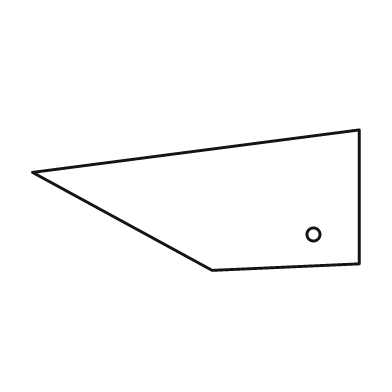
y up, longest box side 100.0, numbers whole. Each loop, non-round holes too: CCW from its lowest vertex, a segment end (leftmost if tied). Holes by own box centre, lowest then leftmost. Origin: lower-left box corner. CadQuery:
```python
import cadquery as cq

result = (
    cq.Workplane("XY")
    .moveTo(55.0, 0.0)
    .lineTo(100.0, 2.0)
    .lineTo(100.0, 43.0)
    .lineTo(0.0, 30.0)
    .close()
    .moveTo(86.0, 11.0)
    .circle(2.0)
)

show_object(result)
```